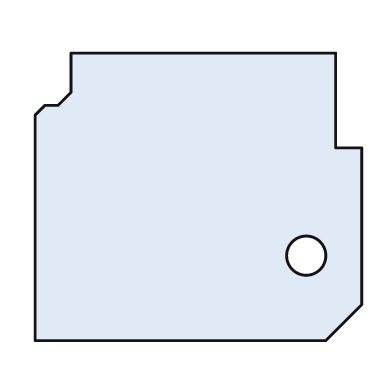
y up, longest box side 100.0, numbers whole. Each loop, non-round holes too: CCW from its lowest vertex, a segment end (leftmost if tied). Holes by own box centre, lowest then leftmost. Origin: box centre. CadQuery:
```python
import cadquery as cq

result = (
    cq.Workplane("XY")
    .moveTo(-50.0, -44.0)
    .lineTo(39.0, -44.0)
    .lineTo(50.0, -33.0)
    .lineTo(50.0, 15.0)
    .lineTo(42.0, 15.0)
    .lineTo(42.0, 44.0)
    .lineTo(-39.0, 44.0)
    .lineTo(-39.0, 32.0)
    .lineTo(-43.0, 28.0)
    .lineTo(-47.0, 28.0)
    .lineTo(-50.0, 25.0)
    .close()
    .moveTo(33.0, -18.0)
    .circle(6.0)
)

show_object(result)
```